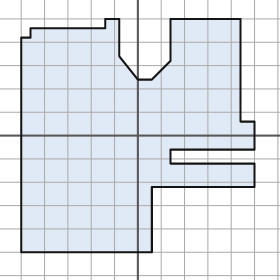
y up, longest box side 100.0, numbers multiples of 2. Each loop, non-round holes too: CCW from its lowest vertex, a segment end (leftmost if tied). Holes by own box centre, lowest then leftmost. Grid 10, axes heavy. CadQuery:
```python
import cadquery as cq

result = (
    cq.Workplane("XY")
    .moveTo(-50.0, -50.0)
    .lineTo(6.0, -50.0)
    .lineTo(6.0, -22.0)
    .lineTo(50.0, -22.0)
    .lineTo(50.0, -12.0)
    .lineTo(14.0, -12.0)
    .lineTo(14.0, -6.0)
    .lineTo(50.0, -6.0)
    .lineTo(50.0, 6.0)
    .lineTo(44.0, 6.0)
    .lineTo(44.0, 50.0)
    .lineTo(14.0, 50.0)
    .lineTo(14.0, 32.0)
    .lineTo(6.0, 24.0)
    .lineTo(0.0, 24.0)
    .lineTo(-8.0, 34.0)
    .lineTo(-8.0, 50.0)
    .lineTo(-14.0, 50.0)
    .lineTo(-14.0, 46.0)
    .lineTo(-46.0, 46.0)
    .lineTo(-46.0, 42.0)
    .lineTo(-50.0, 42.0)
    .close()
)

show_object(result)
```